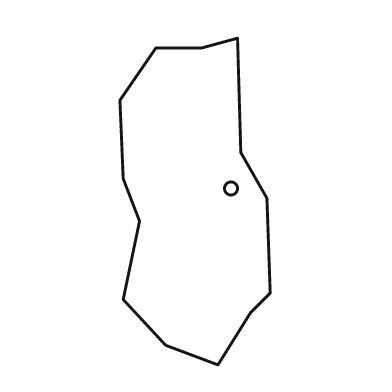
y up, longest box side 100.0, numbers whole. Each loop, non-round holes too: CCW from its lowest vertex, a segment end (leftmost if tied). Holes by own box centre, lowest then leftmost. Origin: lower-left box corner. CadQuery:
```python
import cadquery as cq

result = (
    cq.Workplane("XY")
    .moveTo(30.0, 0.0)
    .lineTo(40.0, 16.0)
    .lineTo(46.0, 22.0)
    .lineTo(45.0, 51.0)
    .lineTo(37.0, 65.0)
    .lineTo(36.0, 100.0)
    .lineTo(25.0, 97.0)
    .lineTo(11.0, 97.0)
    .lineTo(0.0, 81.0)
    .lineTo(1.0, 57.0)
    .lineTo(6.0, 44.0)
    .lineTo(1.0, 20.0)
    .lineTo(14.0, 6.0)
    .close()
    .moveTo(34.0, 54.0)
    .circle(2.0)
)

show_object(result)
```